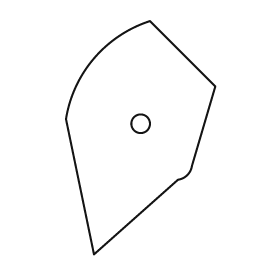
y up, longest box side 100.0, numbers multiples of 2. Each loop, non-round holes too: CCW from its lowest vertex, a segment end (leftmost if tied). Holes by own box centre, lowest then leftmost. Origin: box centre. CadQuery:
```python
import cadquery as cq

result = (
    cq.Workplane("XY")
    .moveTo(-20.0, -50.0)
    .lineTo(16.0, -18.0)
    .threePointArc((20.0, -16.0), (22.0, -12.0))
    .lineTo(32.0, 22.0)
    .lineTo(4.0, 50.0)
    .threePointArc((-20.0, 34.0), (-32.0, 8.0))
    .close()
    .moveTo(0.0, 6.0)
    .circle(4.0)
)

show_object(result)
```